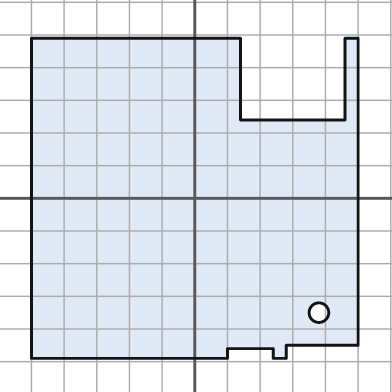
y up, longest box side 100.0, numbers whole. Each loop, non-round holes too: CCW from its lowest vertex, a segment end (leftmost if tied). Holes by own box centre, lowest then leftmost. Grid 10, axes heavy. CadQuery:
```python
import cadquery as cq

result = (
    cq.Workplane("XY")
    .moveTo(-50.0, -49.0)
    .lineTo(10.0, -49.0)
    .lineTo(10.0, -46.0)
    .lineTo(24.0, -46.0)
    .lineTo(24.0, -49.0)
    .lineTo(28.0, -49.0)
    .lineTo(28.0, -45.0)
    .lineTo(50.0, -45.0)
    .lineTo(50.0, 49.0)
    .lineTo(46.0, 49.0)
    .lineTo(46.0, 24.0)
    .lineTo(14.0, 24.0)
    .lineTo(14.0, 49.0)
    .lineTo(-50.0, 49.0)
    .close()
    .moveTo(38.0, -35.0)
    .circle(3.0)
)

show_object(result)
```